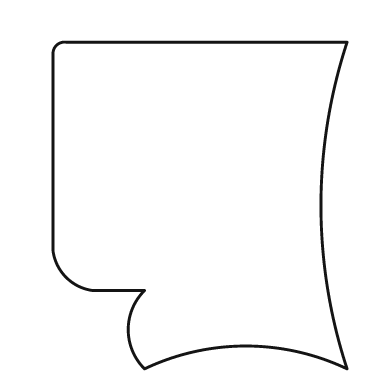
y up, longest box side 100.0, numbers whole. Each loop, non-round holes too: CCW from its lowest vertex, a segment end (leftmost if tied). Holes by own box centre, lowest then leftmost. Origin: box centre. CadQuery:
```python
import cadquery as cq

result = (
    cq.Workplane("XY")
    .moveTo(-17.0, -50.0)
    .threePointArc((14.0, -43.0), (45.0, -50.0))
    .threePointArc((37.0, 0.0), (45.0, 50.0))
    .lineTo(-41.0, 50.0)
    .threePointArc((-44.0, 49.0), (-45.0, 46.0))
    .lineTo(-45.0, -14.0)
    .threePointArc((-41.0, -22.0), (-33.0, -26.0))
    .lineTo(-17.0, -26.0)
    .threePointArc((-22.0, -38.0), (-17.0, -50.0))
    .close()
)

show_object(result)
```